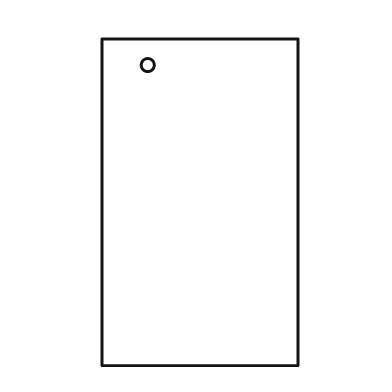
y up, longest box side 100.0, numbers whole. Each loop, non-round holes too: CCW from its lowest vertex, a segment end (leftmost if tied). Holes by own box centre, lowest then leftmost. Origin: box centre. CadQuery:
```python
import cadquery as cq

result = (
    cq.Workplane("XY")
    .moveTo(-30.0, -50.0)
    .lineTo(30.0, -50.0)
    .lineTo(30.0, 50.0)
    .lineTo(-30.0, 50.0)
    .close()
    .moveTo(-16.0, 42.0)
    .circle(2.0)
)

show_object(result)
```